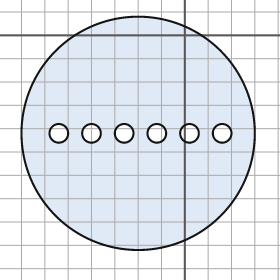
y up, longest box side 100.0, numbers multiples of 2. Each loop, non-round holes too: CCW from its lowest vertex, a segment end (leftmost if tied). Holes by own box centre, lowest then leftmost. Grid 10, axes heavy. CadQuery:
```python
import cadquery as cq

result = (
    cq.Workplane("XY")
    .moveTo(-20.0, -42.0)
    .circle(50.0)
    .moveTo(-54.0, -42.0)
    .circle(4.0)
    .moveTo(-40.0, -42.0)
    .circle(4.0)
    .moveTo(-26.0, -42.0)
    .circle(4.0)
    .moveTo(-12.0, -42.0)
    .circle(4.0)
    .moveTo(2.0, -42.0)
    .circle(4.0)
    .moveTo(16.0, -42.0)
    .circle(4.0)
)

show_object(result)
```